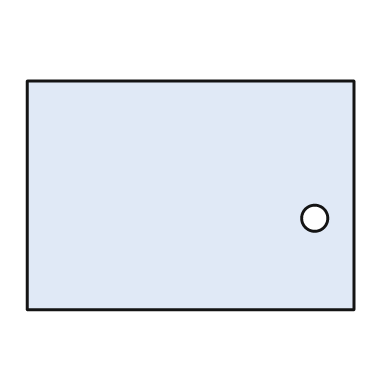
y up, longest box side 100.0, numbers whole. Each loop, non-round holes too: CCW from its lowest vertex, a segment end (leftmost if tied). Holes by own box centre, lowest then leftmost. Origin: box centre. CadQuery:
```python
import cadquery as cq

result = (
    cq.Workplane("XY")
    .moveTo(-50.0, -35.0)
    .lineTo(50.0, -35.0)
    .lineTo(50.0, 35.0)
    .lineTo(-50.0, 35.0)
    .close()
    .moveTo(38.0, -7.0)
    .circle(4.0)
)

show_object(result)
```